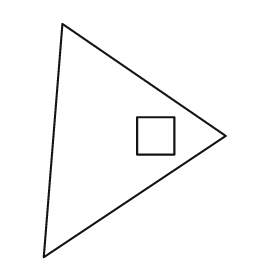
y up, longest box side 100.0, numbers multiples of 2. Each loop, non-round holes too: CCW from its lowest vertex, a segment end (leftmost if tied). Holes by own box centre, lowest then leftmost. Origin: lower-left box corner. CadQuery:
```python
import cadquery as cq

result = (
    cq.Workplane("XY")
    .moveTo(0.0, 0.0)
    .lineTo(78.0, 52.0)
    .lineTo(8.0, 100.0)
    .close()
    .moveTo(40.0, 44.0)
    .lineTo(56.0, 44.0)
    .lineTo(56.0, 60.0)
    .lineTo(40.0, 60.0)
    .close()
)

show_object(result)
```